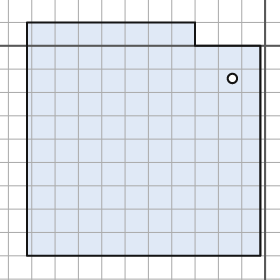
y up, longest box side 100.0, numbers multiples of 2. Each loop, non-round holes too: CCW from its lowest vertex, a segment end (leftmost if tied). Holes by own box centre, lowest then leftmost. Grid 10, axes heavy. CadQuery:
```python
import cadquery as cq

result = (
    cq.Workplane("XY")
    .moveTo(-102.0, -90.0)
    .lineTo(-2.0, -90.0)
    .lineTo(-2.0, 0.0)
    .lineTo(-30.0, 0.0)
    .lineTo(-30.0, 10.0)
    .lineTo(-102.0, 10.0)
    .close()
    .moveTo(-14.0, -14.0)
    .circle(2.0)
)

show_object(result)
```